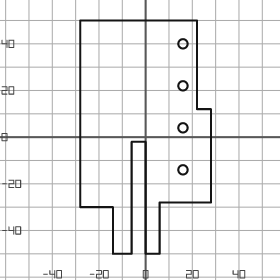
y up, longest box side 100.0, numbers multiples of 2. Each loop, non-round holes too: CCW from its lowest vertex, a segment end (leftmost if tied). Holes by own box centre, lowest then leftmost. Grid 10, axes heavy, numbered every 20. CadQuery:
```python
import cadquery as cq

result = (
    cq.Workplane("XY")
    .moveTo(-14.0, -50.0)
    .lineTo(-6.0, -50.0)
    .lineTo(-6.0, -2.0)
    .lineTo(0.0, -2.0)
    .lineTo(0.0, -50.0)
    .lineTo(6.0, -50.0)
    .lineTo(6.0, -28.0)
    .lineTo(28.0, -28.0)
    .lineTo(28.0, 12.0)
    .lineTo(22.0, 12.0)
    .lineTo(22.0, 50.0)
    .lineTo(-28.0, 50.0)
    .lineTo(-28.0, -30.0)
    .lineTo(-14.0, -30.0)
    .close()
    .moveTo(16.0, -14.0)
    .circle(2.0)
    .moveTo(16.0, 4.0)
    .circle(2.0)
    .moveTo(16.0, 22.0)
    .circle(2.0)
    .moveTo(16.0, 40.0)
    .circle(2.0)
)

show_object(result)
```